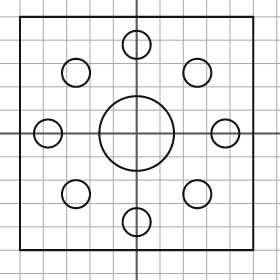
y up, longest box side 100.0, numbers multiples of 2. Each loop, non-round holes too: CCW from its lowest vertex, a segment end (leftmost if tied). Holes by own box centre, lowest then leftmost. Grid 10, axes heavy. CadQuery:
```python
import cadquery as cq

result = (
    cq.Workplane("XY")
    .moveTo(-50.0, -50.0)
    .lineTo(50.0, -50.0)
    .lineTo(50.0, 50.0)
    .lineTo(-50.0, 50.0)
    .close()
    .moveTo(0.0, -38.0)
    .circle(6.0)
    .moveTo(-26.0, -26.0)
    .circle(6.0)
    .moveTo(26.0, -26.0)
    .circle(6.0)
    .moveTo(-38.0, 0.0)
    .circle(6.0)
    .moveTo(0.0, 0.0)
    .circle(16.0)
    .moveTo(38.0, 0.0)
    .circle(6.0)
    .moveTo(-26.0, 26.0)
    .circle(6.0)
    .moveTo(26.0, 26.0)
    .circle(6.0)
    .moveTo(0.0, 38.0)
    .circle(6.0)
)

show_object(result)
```